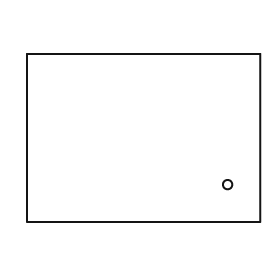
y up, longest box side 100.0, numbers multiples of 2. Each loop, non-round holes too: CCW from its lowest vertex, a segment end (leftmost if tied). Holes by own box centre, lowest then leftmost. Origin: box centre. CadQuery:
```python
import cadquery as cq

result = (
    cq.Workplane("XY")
    .moveTo(-50.0, -36.0)
    .lineTo(50.0, -36.0)
    .lineTo(50.0, 36.0)
    .lineTo(-50.0, 36.0)
    .close()
    .moveTo(36.0, -20.0)
    .circle(2.0)
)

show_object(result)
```